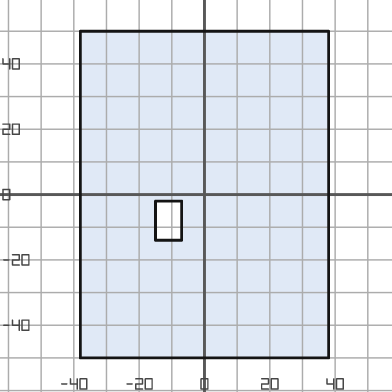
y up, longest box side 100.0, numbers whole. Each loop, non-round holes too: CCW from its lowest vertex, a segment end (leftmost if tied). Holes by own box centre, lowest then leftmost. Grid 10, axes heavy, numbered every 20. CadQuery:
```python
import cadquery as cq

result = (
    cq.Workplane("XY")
    .moveTo(-38.0, -50.0)
    .lineTo(38.0, -50.0)
    .lineTo(38.0, 50.0)
    .lineTo(-38.0, 50.0)
    .close()
    .moveTo(-15.0, -14.0)
    .lineTo(-7.0, -14.0)
    .lineTo(-7.0, -2.0)
    .lineTo(-15.0, -2.0)
    .close()
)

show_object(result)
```